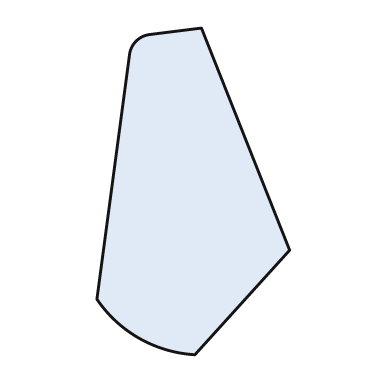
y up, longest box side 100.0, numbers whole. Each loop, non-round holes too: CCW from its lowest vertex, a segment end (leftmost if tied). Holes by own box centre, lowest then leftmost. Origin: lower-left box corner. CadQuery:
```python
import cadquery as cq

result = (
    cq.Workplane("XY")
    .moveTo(30.0, 0.0)
    .lineTo(59.0, 32.0)
    .lineTo(32.0, 100.0)
    .lineTo(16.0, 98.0)
    .threePointArc((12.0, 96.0), (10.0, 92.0))
    .lineTo(0.0, 17.0)
    .threePointArc((13.0, 5.0), (30.0, 0.0))
    .close()
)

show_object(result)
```